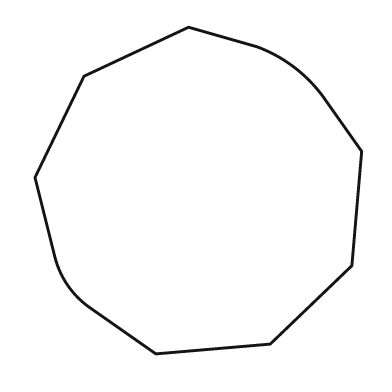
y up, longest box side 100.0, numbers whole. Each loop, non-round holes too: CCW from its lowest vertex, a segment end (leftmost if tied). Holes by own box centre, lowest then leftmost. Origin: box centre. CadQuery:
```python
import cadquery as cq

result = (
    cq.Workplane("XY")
    .moveTo(-13.0, -50.0)
    .lineTo(22.0, -47.0)
    .lineTo(47.0, -23.0)
    .lineTo(50.0, 12.0)
    .lineTo(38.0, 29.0)
    .threePointArc((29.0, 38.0), (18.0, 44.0))
    .lineTo(-3.0, 50.0)
    .lineTo(-35.0, 35.0)
    .lineTo(-50.0, 4.0)
    .lineTo(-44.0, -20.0)
    .threePointArc((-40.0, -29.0), (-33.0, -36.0))
    .close()
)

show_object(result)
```